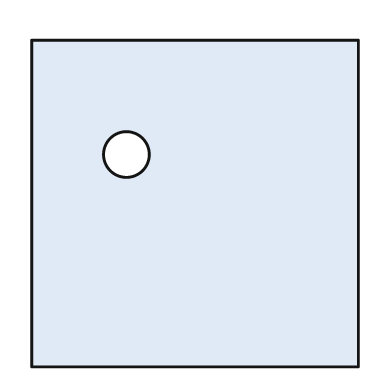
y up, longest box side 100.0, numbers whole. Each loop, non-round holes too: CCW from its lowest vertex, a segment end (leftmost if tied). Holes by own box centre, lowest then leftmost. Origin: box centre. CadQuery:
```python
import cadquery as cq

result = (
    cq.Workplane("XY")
    .moveTo(-50.0, -50.0)
    .lineTo(50.0, -50.0)
    .lineTo(50.0, 50.0)
    .lineTo(-50.0, 50.0)
    .close()
    .moveTo(-21.0, 15.0)
    .circle(7.0)
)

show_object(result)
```